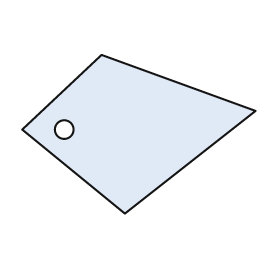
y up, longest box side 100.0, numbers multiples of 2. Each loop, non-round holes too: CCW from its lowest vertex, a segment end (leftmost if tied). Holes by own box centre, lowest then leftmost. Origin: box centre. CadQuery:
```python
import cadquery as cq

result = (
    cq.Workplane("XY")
    .moveTo(-6.0, -34.0)
    .lineTo(50.0, 10.0)
    .lineTo(-16.0, 34.0)
    .lineTo(-50.0, 2.0)
    .close()
    .moveTo(-32.0, 2.0)
    .circle(4.0)
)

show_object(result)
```